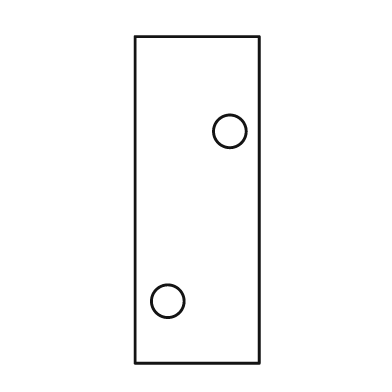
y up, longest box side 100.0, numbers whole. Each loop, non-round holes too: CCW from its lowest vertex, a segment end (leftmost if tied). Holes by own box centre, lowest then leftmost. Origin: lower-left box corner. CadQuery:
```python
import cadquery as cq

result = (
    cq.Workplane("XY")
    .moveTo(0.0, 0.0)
    .lineTo(38.0, 0.0)
    .lineTo(38.0, 100.0)
    .lineTo(0.0, 100.0)
    .close()
    .moveTo(10.0, 19.0)
    .circle(5.0)
    .moveTo(29.0, 71.0)
    .circle(5.0)
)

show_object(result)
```